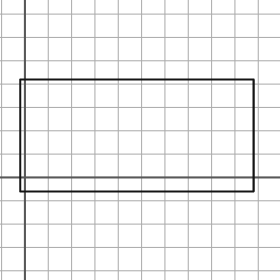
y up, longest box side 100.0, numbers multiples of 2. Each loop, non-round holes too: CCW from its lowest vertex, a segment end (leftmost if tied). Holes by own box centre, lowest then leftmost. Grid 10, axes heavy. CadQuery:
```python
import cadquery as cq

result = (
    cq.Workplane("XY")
    .moveTo(-2.0, -6.0)
    .lineTo(98.0, -6.0)
    .lineTo(98.0, 42.0)
    .lineTo(-2.0, 42.0)
    .close()
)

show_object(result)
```